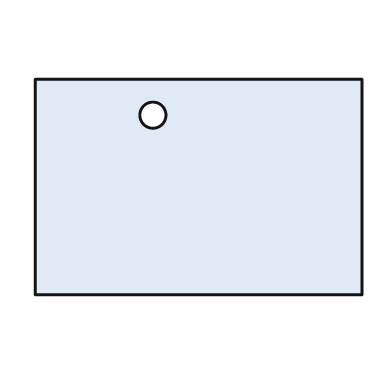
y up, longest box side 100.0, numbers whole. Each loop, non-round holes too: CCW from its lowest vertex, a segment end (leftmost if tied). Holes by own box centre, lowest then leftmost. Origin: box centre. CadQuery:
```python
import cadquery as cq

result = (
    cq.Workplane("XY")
    .moveTo(-50.0, -33.0)
    .lineTo(50.0, -33.0)
    .lineTo(50.0, 33.0)
    .lineTo(-50.0, 33.0)
    .close()
    .moveTo(-14.0, 22.0)
    .circle(4.0)
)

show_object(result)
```